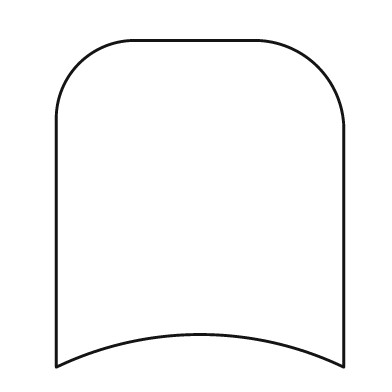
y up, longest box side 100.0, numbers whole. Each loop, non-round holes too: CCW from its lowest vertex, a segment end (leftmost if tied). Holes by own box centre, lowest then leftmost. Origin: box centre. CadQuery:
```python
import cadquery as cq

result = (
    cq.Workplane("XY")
    .moveTo(-44.0, -50.0)
    .threePointArc((0.0, -40.0), (44.0, -50.0))
    .lineTo(44.0, 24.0)
    .threePointArc((36.0, 42.0), (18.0, 50.0))
    .lineTo(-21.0, 50.0)
    .threePointArc((-37.0, 43.0), (-44.0, 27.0))
    .close()
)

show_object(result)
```